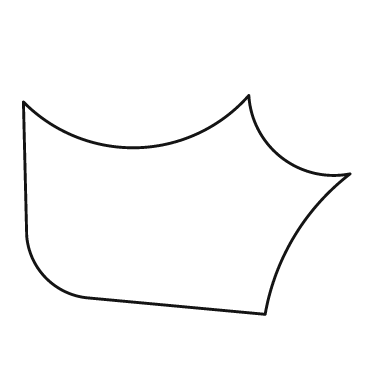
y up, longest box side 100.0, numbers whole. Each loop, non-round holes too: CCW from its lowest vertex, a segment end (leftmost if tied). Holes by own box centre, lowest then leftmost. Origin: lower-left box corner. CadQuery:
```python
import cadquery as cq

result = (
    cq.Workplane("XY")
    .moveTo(74.0, 0.0)
    .threePointArc((83.0, 24.0), (100.0, 43.0))
    .threePointArc((79.0, 48.0), (69.0, 67.0))
    .threePointArc((35.0, 51.0), (0.0, 65.0))
    .lineTo(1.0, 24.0)
    .threePointArc((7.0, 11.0), (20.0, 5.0))
    .close()
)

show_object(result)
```